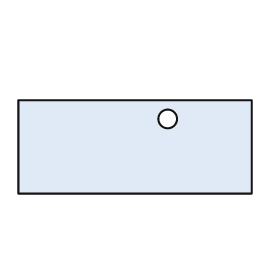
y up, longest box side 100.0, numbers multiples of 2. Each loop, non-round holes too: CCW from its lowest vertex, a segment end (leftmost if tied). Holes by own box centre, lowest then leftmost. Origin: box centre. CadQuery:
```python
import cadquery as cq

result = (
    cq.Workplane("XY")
    .moveTo(-50.0, -20.0)
    .lineTo(50.0, -20.0)
    .lineTo(50.0, 20.0)
    .lineTo(-50.0, 20.0)
    .close()
    .moveTo(14.0, 12.0)
    .circle(4.0)
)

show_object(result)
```